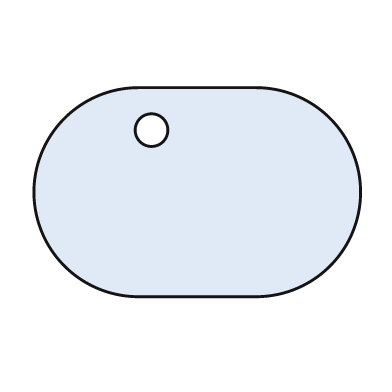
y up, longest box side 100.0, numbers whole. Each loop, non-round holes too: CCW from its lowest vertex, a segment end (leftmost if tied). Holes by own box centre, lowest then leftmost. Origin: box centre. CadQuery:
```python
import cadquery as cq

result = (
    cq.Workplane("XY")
    .moveTo(-18.0, -32.0)
    .lineTo(18.0, -32.0)
    .threePointArc((50.0, 0.0), (18.0, 32.0))
    .lineTo(-18.0, 32.0)
    .threePointArc((-50.0, 0.0), (-18.0, -32.0))
    .close()
    .moveTo(-14.0, 19.0)
    .circle(5.0)
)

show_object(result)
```